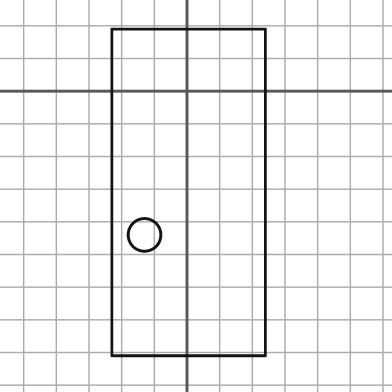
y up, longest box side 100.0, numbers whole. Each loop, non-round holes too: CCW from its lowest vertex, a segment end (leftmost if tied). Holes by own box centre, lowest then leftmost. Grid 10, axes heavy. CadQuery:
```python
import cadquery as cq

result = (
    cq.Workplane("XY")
    .moveTo(-23.0, -81.0)
    .lineTo(24.0, -81.0)
    .lineTo(24.0, 19.0)
    .lineTo(-23.0, 19.0)
    .close()
    .moveTo(-13.0, -44.0)
    .circle(5.0)
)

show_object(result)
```